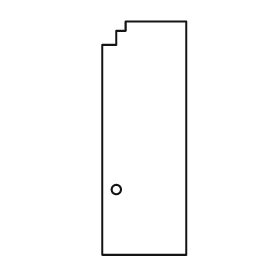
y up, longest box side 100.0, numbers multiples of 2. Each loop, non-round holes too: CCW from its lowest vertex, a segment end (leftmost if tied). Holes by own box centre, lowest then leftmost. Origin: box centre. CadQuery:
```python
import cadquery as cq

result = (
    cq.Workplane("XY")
    .moveTo(-18.0, -50.0)
    .lineTo(18.0, -50.0)
    .lineTo(18.0, 50.0)
    .lineTo(-8.0, 50.0)
    .lineTo(-8.0, 46.0)
    .lineTo(-12.0, 46.0)
    .lineTo(-12.0, 40.0)
    .lineTo(-18.0, 40.0)
    .close()
    .moveTo(-12.0, -22.0)
    .circle(2.0)
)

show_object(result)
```